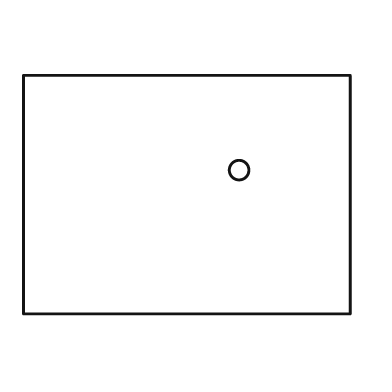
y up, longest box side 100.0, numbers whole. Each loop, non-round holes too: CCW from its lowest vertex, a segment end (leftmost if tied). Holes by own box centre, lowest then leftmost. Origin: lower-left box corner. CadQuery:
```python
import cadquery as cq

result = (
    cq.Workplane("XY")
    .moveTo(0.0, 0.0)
    .lineTo(100.0, 0.0)
    .lineTo(100.0, 73.0)
    .lineTo(0.0, 73.0)
    .close()
    .moveTo(66.0, 44.0)
    .circle(3.0)
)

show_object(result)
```